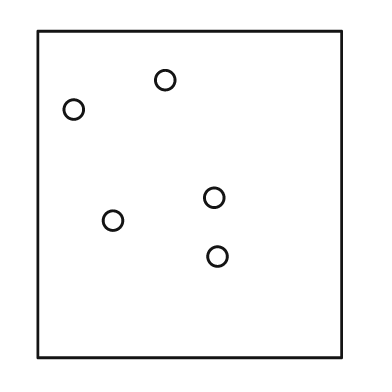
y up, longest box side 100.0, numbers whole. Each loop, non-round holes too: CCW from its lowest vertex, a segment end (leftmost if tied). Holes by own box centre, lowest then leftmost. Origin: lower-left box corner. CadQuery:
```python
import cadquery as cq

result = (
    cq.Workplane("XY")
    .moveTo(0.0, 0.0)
    .lineTo(93.0, 0.0)
    .lineTo(93.0, 100.0)
    .lineTo(0.0, 100.0)
    .close()
    .moveTo(55.0, 31.0)
    .circle(3.0)
    .moveTo(23.0, 42.0)
    .circle(3.0)
    .moveTo(54.0, 49.0)
    .circle(3.0)
    .moveTo(11.0, 76.0)
    .circle(3.0)
    .moveTo(39.0, 85.0)
    .circle(3.0)
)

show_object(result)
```